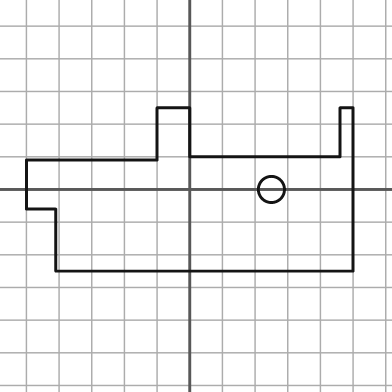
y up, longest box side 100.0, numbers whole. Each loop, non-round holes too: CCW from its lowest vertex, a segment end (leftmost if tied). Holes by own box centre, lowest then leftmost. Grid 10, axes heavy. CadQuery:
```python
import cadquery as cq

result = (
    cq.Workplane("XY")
    .moveTo(-41.0, -25.0)
    .lineTo(50.0, -25.0)
    .lineTo(50.0, 25.0)
    .lineTo(46.0, 25.0)
    .lineTo(46.0, 10.0)
    .lineTo(0.0, 10.0)
    .lineTo(0.0, 25.0)
    .lineTo(-10.0, 25.0)
    .lineTo(-10.0, 9.0)
    .lineTo(-50.0, 9.0)
    .lineTo(-50.0, -6.0)
    .lineTo(-41.0, -6.0)
    .close()
    .moveTo(25.0, 0.0)
    .circle(4.0)
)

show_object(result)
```